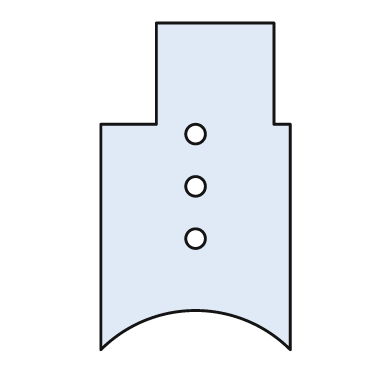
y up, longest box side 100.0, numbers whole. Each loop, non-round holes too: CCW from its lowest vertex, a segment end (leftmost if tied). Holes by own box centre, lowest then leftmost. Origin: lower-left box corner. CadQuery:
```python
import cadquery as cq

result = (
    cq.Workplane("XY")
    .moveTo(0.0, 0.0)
    .threePointArc((29.0, 12.0), (58.0, 0.0))
    .lineTo(58.0, 69.0)
    .lineTo(53.0, 69.0)
    .lineTo(53.0, 100.0)
    .lineTo(17.0, 100.0)
    .lineTo(17.0, 69.0)
    .lineTo(0.0, 69.0)
    .close()
    .moveTo(29.0, 34.0)
    .circle(3.0)
    .moveTo(29.0, 50.0)
    .circle(3.0)
    .moveTo(29.0, 66.0)
    .circle(3.0)
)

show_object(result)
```